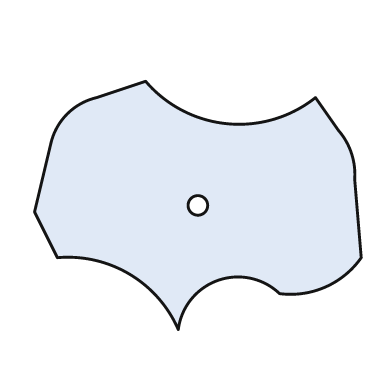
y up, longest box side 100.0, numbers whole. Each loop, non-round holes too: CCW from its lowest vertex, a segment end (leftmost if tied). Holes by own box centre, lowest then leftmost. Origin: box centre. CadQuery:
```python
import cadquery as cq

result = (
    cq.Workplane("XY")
    .moveTo(-6.0, -38.0)
    .threePointArc((6.0, -23.0), (25.0, -27.0))
    .threePointArc((39.0, -25.0), (50.0, -16.0))
    .lineTo(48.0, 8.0)
    .threePointArc((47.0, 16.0), (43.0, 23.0))
    .lineTo(36.0, 33.0)
    .threePointArc((9.0, 25.0), (-16.0, 38.0))
    .lineTo(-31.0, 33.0)
    .threePointArc((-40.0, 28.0), (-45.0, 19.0))
    .lineTo(-50.0, -2.0)
    .lineTo(-43.0, -16.0)
    .threePointArc((-21.0, -21.0), (-6.0, -38.0))
    .close()
    .moveTo(0.0, 0.0)
    .circle(3.0)
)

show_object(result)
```